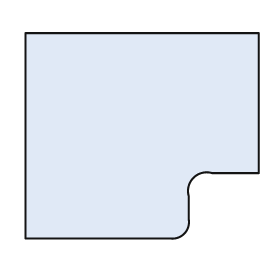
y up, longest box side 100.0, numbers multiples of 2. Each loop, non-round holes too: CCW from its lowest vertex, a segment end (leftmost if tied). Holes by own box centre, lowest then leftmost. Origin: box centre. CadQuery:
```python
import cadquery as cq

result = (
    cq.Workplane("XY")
    .moveTo(-50.0, -44.0)
    .lineTo(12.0, -44.0)
    .threePointArc((18.0, -42.0), (20.0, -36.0))
    .lineTo(20.0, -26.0)
    .threePointArc((22.0, -18.0), (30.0, -16.0))
    .lineTo(50.0, -16.0)
    .lineTo(50.0, 44.0)
    .lineTo(-50.0, 44.0)
    .close()
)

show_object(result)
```